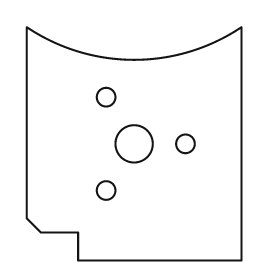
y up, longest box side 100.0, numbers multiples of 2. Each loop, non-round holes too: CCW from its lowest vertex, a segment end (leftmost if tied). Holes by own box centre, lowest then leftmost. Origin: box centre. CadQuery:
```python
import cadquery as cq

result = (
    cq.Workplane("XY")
    .moveTo(-24.0, -50.0)
    .lineTo(46.0, -50.0)
    .lineTo(46.0, 50.0)
    .threePointArc((0.0, 36.0), (-46.0, 50.0))
    .lineTo(-46.0, -32.0)
    .lineTo(-40.0, -38.0)
    .lineTo(-24.0, -38.0)
    .close()
    .moveTo(-12.0, -20.0)
    .circle(4.0)
    .moveTo(0.0, 0.0)
    .circle(8.0)
    .moveTo(22.0, 0.0)
    .circle(4.0)
    .moveTo(-12.0, 20.0)
    .circle(4.0)
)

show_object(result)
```